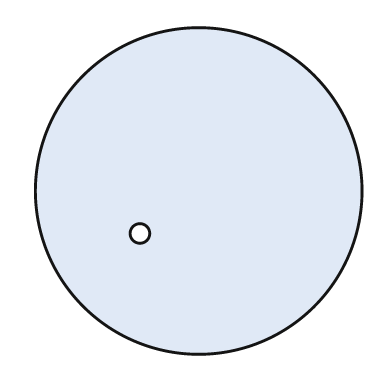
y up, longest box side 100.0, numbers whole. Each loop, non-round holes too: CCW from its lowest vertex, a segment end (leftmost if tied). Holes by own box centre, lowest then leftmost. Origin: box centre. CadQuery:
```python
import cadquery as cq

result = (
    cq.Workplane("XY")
    .moveTo(0.0, 0.0)
    .circle(50.0)
    .moveTo(-18.0, -13.0)
    .circle(3.0)
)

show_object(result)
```